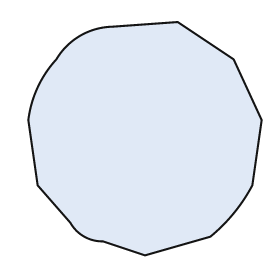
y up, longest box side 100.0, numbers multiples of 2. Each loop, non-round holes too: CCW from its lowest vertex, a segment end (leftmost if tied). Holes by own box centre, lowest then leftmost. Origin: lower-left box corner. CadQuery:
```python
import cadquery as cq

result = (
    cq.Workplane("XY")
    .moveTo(50.0, 0.0)
    .lineTo(78.0, 8.0)
    .threePointArc((88.0, 18.0), (96.0, 30.0))
    .lineTo(100.0, 58.0)
    .lineTo(88.0, 84.0)
    .lineTo(64.0, 100.0)
    .lineTo(36.0, 98.0)
    .threePointArc((22.0, 94.0), (12.0, 84.0))
    .threePointArc((4.0, 72.0), (0.0, 58.0))
    .lineTo(4.0, 30.0)
    .lineTo(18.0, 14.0)
    .threePointArc((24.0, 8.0), (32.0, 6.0))
    .close()
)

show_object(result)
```